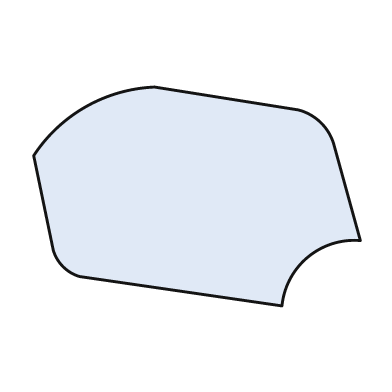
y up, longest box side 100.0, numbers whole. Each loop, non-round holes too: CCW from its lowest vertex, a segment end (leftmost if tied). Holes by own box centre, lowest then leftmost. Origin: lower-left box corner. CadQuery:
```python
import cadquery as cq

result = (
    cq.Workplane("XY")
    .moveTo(76.0, 0.0)
    .threePointArc((84.0, 15.0), (100.0, 20.0))
    .lineTo(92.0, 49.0)
    .threePointArc((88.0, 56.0), (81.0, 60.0))
    .lineTo(37.0, 67.0)
    .threePointArc((16.0, 61.0), (0.0, 46.0))
    .lineTo(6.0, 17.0)
    .threePointArc((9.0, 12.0), (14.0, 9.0))
    .close()
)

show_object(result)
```